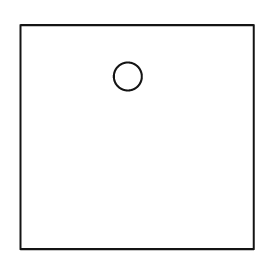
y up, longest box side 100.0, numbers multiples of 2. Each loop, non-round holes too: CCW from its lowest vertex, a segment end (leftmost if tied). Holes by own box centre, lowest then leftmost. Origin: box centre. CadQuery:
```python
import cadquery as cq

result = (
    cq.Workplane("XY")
    .moveTo(-50.0, -48.0)
    .lineTo(50.0, -48.0)
    .lineTo(50.0, 48.0)
    .lineTo(-50.0, 48.0)
    .close()
    .moveTo(-4.0, 26.0)
    .circle(6.0)
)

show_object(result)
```